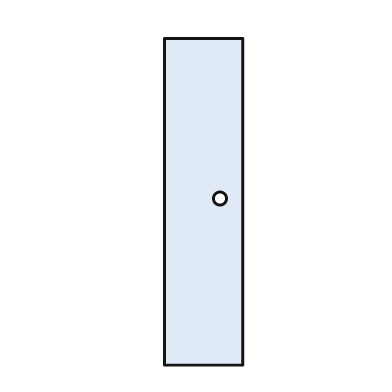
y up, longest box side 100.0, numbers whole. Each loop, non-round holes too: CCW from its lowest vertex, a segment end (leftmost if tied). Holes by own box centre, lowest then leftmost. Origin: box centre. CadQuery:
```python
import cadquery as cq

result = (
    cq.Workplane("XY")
    .moveTo(-12.0, -50.0)
    .lineTo(12.0, -50.0)
    .lineTo(12.0, 50.0)
    .lineTo(-12.0, 50.0)
    .close()
    .moveTo(5.0, 1.0)
    .circle(2.0)
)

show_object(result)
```